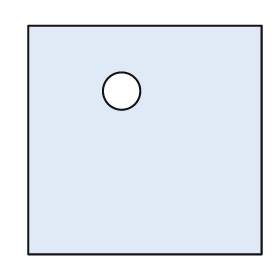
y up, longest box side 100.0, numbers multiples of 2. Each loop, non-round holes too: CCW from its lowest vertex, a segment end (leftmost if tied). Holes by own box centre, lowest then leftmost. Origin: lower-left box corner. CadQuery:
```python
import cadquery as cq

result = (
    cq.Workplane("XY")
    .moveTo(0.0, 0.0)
    .lineTo(100.0, 0.0)
    .lineTo(100.0, 98.0)
    .lineTo(0.0, 98.0)
    .close()
    .moveTo(40.0, 70.0)
    .circle(8.0)
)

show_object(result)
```